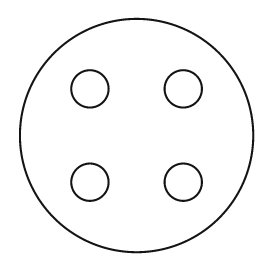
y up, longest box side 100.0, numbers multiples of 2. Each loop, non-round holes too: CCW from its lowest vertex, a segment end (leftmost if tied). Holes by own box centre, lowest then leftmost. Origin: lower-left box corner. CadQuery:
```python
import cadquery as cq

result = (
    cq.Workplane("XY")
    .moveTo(50.0, 50.0)
    .circle(50.0)
    .moveTo(30.0, 30.0)
    .circle(8.0)
    .moveTo(70.0, 30.0)
    .circle(8.0)
    .moveTo(30.0, 70.0)
    .circle(8.0)
    .moveTo(70.0, 70.0)
    .circle(8.0)
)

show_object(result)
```